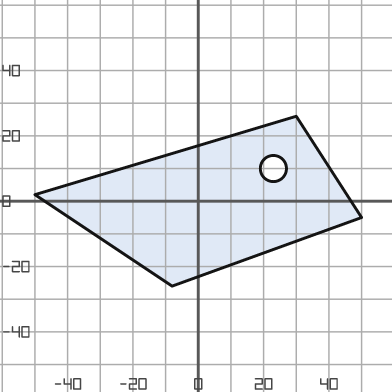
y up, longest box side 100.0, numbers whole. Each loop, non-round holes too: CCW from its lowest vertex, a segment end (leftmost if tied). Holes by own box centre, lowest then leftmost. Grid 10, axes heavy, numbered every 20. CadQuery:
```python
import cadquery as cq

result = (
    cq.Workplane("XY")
    .moveTo(-8.0, -26.0)
    .lineTo(50.0, -5.0)
    .lineTo(30.0, 26.0)
    .lineTo(-50.0, 2.0)
    .close()
    .moveTo(23.0, 10.0)
    .circle(4.0)
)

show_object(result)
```